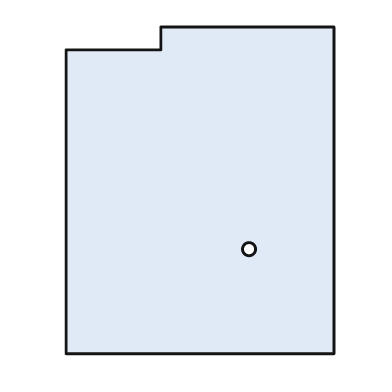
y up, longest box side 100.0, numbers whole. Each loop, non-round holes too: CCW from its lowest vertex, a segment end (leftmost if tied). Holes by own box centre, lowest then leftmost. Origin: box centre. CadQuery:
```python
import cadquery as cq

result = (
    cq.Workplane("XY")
    .moveTo(-41.0, -50.0)
    .lineTo(41.0, -50.0)
    .lineTo(41.0, 50.0)
    .lineTo(-12.0, 50.0)
    .lineTo(-12.0, 43.0)
    .lineTo(-41.0, 43.0)
    .close()
    .moveTo(15.0, -18.0)
    .circle(2.0)
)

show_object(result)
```